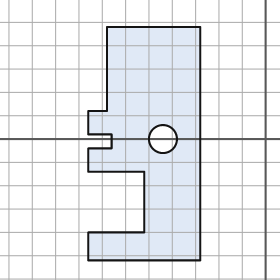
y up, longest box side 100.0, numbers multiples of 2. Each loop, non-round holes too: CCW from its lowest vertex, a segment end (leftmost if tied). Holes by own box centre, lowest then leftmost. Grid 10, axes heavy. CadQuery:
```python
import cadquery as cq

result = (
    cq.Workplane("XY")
    .moveTo(-76.0, -52.0)
    .lineTo(-28.0, -52.0)
    .lineTo(-28.0, 48.0)
    .lineTo(-68.0, 48.0)
    .lineTo(-68.0, 12.0)
    .lineTo(-76.0, 12.0)
    .lineTo(-76.0, 2.0)
    .lineTo(-66.0, 2.0)
    .lineTo(-66.0, -4.0)
    .lineTo(-76.0, -4.0)
    .lineTo(-76.0, -14.0)
    .lineTo(-52.0, -14.0)
    .lineTo(-52.0, -40.0)
    .lineTo(-76.0, -40.0)
    .close()
    .moveTo(-44.0, 0.0)
    .circle(6.0)
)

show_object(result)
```